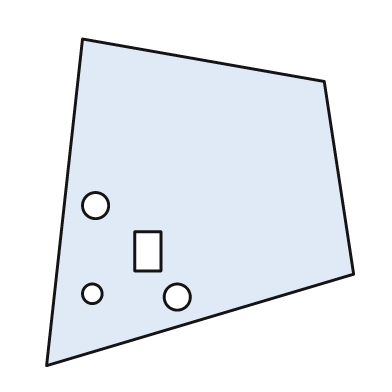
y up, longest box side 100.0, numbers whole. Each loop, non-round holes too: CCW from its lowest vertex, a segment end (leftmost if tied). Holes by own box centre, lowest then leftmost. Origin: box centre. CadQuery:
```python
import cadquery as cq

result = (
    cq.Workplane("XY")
    .moveTo(-47.0, -50.0)
    .lineTo(47.0, -22.0)
    .lineTo(38.0, 37.0)
    .lineTo(-36.0, 50.0)
    .close()
    .moveTo(-7.0, -29.0)
    .circle(4.0)
    .moveTo(-33.0, -28.0)
    .circle(3.0)
    .moveTo(-20.0, -21.0)
    .lineTo(-12.0, -21.0)
    .lineTo(-12.0, -9.0)
    .lineTo(-20.0, -9.0)
    .close()
    .moveTo(-32.0, -1.0)
    .circle(4.0)
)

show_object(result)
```